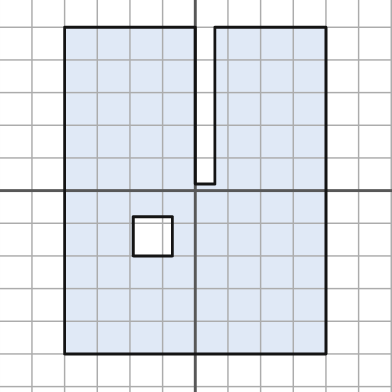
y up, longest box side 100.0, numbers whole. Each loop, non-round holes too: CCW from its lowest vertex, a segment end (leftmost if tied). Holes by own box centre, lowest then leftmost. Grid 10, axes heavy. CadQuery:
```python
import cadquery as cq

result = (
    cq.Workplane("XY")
    .moveTo(-40.0, -50.0)
    .lineTo(40.0, -50.0)
    .lineTo(40.0, 50.0)
    .lineTo(6.0, 50.0)
    .lineTo(6.0, 2.0)
    .lineTo(0.0, 2.0)
    .lineTo(0.0, 50.0)
    .lineTo(-40.0, 50.0)
    .close()
    .moveTo(-19.0, -20.0)
    .lineTo(-7.0, -20.0)
    .lineTo(-7.0, -8.0)
    .lineTo(-19.0, -8.0)
    .close()
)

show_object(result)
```